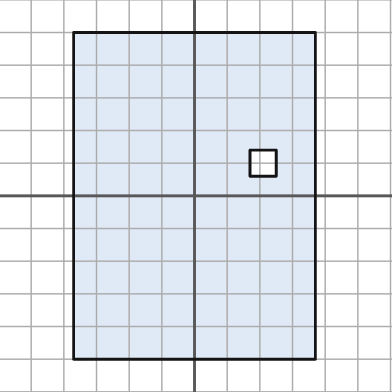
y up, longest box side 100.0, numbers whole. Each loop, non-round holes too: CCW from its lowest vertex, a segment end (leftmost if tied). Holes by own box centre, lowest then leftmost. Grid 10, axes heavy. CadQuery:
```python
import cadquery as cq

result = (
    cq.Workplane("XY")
    .moveTo(-37.0, -50.0)
    .lineTo(37.0, -50.0)
    .lineTo(37.0, 50.0)
    .lineTo(-37.0, 50.0)
    .close()
    .moveTo(17.0, 6.0)
    .lineTo(25.0, 6.0)
    .lineTo(25.0, 14.0)
    .lineTo(17.0, 14.0)
    .close()
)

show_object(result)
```